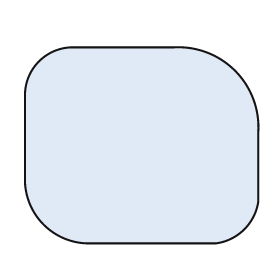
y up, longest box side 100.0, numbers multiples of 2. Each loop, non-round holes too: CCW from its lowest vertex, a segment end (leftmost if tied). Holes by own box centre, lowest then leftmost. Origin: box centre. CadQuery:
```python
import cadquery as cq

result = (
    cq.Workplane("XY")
    .moveTo(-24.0, -42.0)
    .lineTo(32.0, -42.0)
    .threePointArc((44.0, -36.0), (50.0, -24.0))
    .lineTo(50.0, 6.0)
    .threePointArc((40.0, 32.0), (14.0, 42.0))
    .lineTo(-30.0, 42.0)
    .threePointArc((-44.0, 36.0), (-50.0, 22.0))
    .lineTo(-50.0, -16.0)
    .threePointArc((-42.0, -34.0), (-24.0, -42.0))
    .close()
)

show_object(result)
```